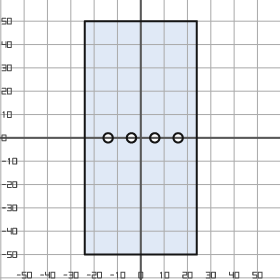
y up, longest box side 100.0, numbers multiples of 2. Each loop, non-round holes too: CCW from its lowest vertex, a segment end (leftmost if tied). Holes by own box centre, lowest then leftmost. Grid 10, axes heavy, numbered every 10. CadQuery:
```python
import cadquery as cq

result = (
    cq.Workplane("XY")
    .moveTo(-24.0, -50.0)
    .lineTo(24.0, -50.0)
    .lineTo(24.0, 50.0)
    .lineTo(-24.0, 50.0)
    .close()
    .moveTo(-14.0, 0.0)
    .circle(2.0)
    .moveTo(-4.0, 0.0)
    .circle(2.0)
    .moveTo(6.0, 0.0)
    .circle(2.0)
    .moveTo(16.0, 0.0)
    .circle(2.0)
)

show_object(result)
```